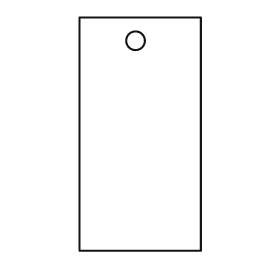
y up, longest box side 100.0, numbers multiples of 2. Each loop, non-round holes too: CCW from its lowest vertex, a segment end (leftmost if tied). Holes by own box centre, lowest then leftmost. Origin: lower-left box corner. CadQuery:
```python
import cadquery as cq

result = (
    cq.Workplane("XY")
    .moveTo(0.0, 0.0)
    .lineTo(52.0, 0.0)
    .lineTo(52.0, 100.0)
    .lineTo(0.0, 100.0)
    .close()
    .moveTo(24.0, 90.0)
    .circle(4.0)
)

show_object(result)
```